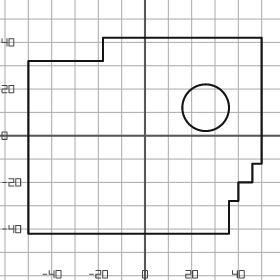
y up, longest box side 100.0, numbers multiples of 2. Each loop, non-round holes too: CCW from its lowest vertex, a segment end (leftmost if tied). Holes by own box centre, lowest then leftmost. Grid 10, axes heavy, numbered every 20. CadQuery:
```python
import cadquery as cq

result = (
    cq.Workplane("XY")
    .moveTo(-50.0, -42.0)
    .lineTo(36.0, -42.0)
    .lineTo(36.0, -28.0)
    .lineTo(40.0, -28.0)
    .lineTo(40.0, -20.0)
    .lineTo(46.0, -20.0)
    .lineTo(46.0, -12.0)
    .lineTo(50.0, -12.0)
    .lineTo(50.0, 42.0)
    .lineTo(-18.0, 42.0)
    .lineTo(-18.0, 32.0)
    .lineTo(-50.0, 32.0)
    .close()
    .moveTo(26.0, 12.0)
    .circle(10.0)
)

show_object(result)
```